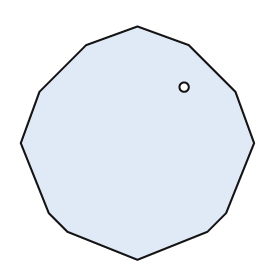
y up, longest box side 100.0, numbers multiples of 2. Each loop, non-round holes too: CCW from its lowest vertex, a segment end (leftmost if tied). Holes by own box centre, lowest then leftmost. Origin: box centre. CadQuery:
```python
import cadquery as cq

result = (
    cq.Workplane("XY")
    .moveTo(0.0, -50.0)
    .lineTo(30.0, -38.0)
    .lineTo(38.0, -30.0)
    .lineTo(50.0, 0.0)
    .lineTo(42.0, 22.0)
    .lineTo(22.0, 42.0)
    .lineTo(0.0, 50.0)
    .lineTo(-22.0, 42.0)
    .lineTo(-42.0, 22.0)
    .lineTo(-50.0, 0.0)
    .lineTo(-38.0, -30.0)
    .lineTo(-30.0, -38.0)
    .close()
    .moveTo(20.0, 24.0)
    .circle(2.0)
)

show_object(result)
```